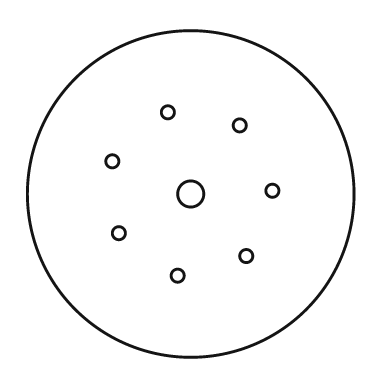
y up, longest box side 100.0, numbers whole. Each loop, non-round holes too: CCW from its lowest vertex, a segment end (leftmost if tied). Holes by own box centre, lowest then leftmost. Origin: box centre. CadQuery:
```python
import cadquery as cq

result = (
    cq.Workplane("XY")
    .moveTo(0.0, 0.0)
    .circle(50.0)
    .moveTo(-4.0, -25.0)
    .circle(2.0)
    .moveTo(17.0, -19.0)
    .circle(2.0)
    .moveTo(-22.0, -12.0)
    .circle(2.0)
    .moveTo(0.0, 0.0)
    .circle(4.0)
    .moveTo(25.0, 1.0)
    .circle(2.0)
    .moveTo(-24.0, 10.0)
    .circle(2.0)
    .moveTo(15.0, 21.0)
    .circle(2.0)
    .moveTo(-7.0, 25.0)
    .circle(2.0)
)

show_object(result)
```